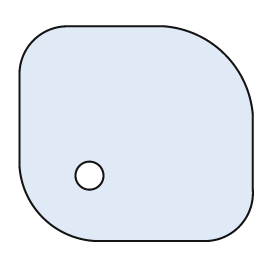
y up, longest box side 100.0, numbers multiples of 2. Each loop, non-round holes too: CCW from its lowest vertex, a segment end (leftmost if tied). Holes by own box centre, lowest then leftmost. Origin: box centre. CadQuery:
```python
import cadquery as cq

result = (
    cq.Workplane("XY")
    .moveTo(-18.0, -46.0)
    .lineTo(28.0, -46.0)
    .threePointArc((44.0, -40.0), (50.0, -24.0))
    .lineTo(50.0, 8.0)
    .threePointArc((38.0, 34.0), (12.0, 46.0))
    .lineTo(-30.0, 46.0)
    .threePointArc((-44.0, 40.0), (-50.0, 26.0))
    .lineTo(-50.0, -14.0)
    .threePointArc((-40.0, -36.0), (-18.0, -46.0))
    .close()
    .moveTo(-20.0, -18.0)
    .circle(6.0)
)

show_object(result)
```